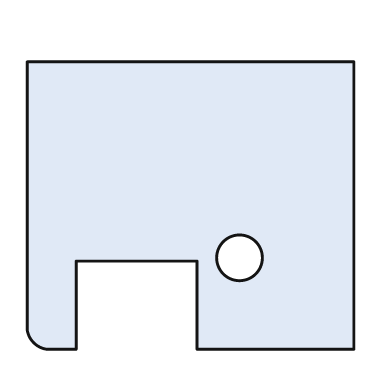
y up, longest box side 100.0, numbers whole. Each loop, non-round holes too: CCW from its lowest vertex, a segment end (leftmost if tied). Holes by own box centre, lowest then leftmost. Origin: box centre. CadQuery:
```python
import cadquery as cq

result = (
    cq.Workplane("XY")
    .moveTo(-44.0, -44.0)
    .lineTo(-35.0, -44.0)
    .lineTo(-35.0, -17.0)
    .lineTo(2.0, -17.0)
    .lineTo(2.0, -44.0)
    .lineTo(50.0, -44.0)
    .lineTo(50.0, 44.0)
    .lineTo(-50.0, 44.0)
    .lineTo(-50.0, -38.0)
    .threePointArc((-48.0, -42.0), (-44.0, -44.0))
    .close()
    .moveTo(15.0, -16.0)
    .circle(7.0)
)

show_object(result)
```